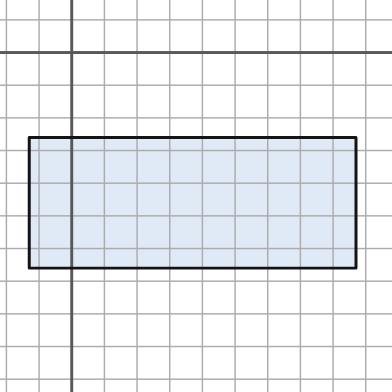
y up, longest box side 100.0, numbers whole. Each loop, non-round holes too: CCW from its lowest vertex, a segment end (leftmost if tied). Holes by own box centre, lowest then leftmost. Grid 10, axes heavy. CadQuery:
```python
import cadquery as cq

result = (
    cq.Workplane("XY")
    .moveTo(-13.0, -66.0)
    .lineTo(87.0, -66.0)
    .lineTo(87.0, -26.0)
    .lineTo(-13.0, -26.0)
    .close()
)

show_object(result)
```